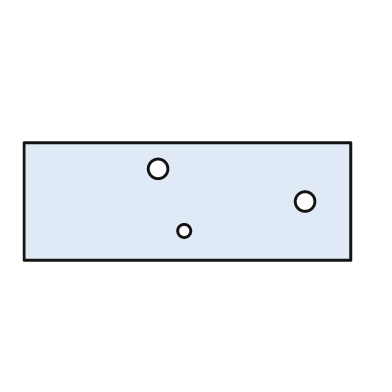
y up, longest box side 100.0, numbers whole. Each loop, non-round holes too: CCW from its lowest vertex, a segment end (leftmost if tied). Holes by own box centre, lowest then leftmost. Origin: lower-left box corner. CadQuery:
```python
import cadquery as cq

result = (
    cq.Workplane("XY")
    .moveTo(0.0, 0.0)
    .lineTo(100.0, 0.0)
    .lineTo(100.0, 36.0)
    .lineTo(0.0, 36.0)
    .close()
    .moveTo(49.0, 9.0)
    .circle(2.0)
    .moveTo(86.0, 18.0)
    .circle(3.0)
    .moveTo(41.0, 28.0)
    .circle(3.0)
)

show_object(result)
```